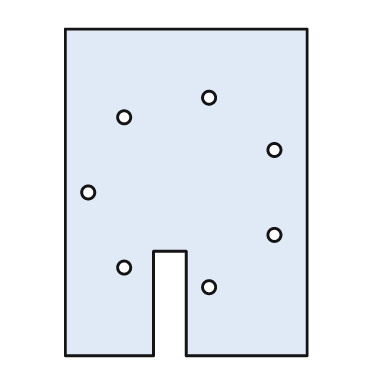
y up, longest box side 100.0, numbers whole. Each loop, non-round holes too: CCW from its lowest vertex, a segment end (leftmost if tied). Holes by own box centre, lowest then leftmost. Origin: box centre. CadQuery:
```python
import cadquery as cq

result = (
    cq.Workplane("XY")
    .moveTo(-37.0, -50.0)
    .lineTo(-10.0, -50.0)
    .lineTo(-10.0, -18.0)
    .lineTo(0.0, -18.0)
    .lineTo(0.0, -50.0)
    .lineTo(37.0, -50.0)
    .lineTo(37.0, 50.0)
    .lineTo(-37.0, 50.0)
    .close()
    .moveTo(7.0, -29.0)
    .circle(2.0)
    .moveTo(-19.0, -23.0)
    .circle(2.0)
    .moveTo(27.0, -13.0)
    .circle(2.0)
    .moveTo(-30.0, 0.0)
    .circle(2.0)
    .moveTo(27.0, 13.0)
    .circle(2.0)
    .moveTo(-19.0, 23.0)
    .circle(2.0)
    .moveTo(7.0, 29.0)
    .circle(2.0)
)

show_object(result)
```